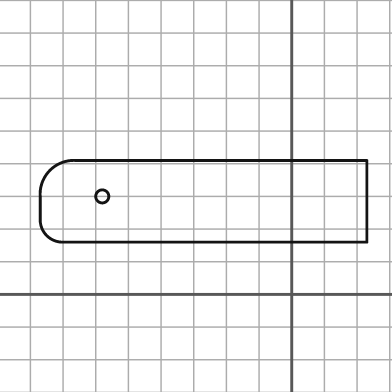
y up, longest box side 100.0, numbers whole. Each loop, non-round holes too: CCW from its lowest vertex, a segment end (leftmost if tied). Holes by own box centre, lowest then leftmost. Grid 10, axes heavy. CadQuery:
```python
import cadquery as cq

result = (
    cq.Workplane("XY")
    .moveTo(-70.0, 16.0)
    .lineTo(23.0, 16.0)
    .lineTo(23.0, 41.0)
    .lineTo(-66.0, 41.0)
    .threePointArc((-74.0, 38.0), (-77.0, 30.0))
    .lineTo(-77.0, 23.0)
    .threePointArc((-75.0, 18.0), (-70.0, 16.0))
    .close()
    .moveTo(-58.0, 30.0)
    .circle(2.0)
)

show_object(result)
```